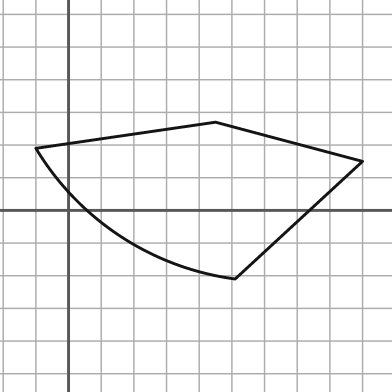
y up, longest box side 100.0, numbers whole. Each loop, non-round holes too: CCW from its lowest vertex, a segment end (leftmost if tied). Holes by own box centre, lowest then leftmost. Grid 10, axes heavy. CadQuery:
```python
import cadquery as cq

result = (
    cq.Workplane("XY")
    .moveTo(51.0, -21.0)
    .lineTo(90.0, 15.0)
    .lineTo(45.0, 27.0)
    .lineTo(-10.0, 19.0)
    .threePointArc((16.0, -8.0), (51.0, -21.0))
    .close()
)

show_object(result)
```